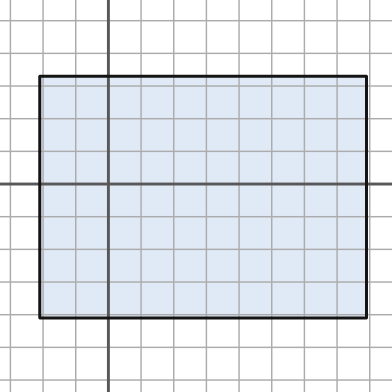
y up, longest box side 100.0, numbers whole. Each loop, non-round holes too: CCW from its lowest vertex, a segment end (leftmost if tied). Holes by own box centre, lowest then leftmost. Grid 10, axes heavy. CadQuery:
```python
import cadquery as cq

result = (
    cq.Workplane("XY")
    .moveTo(-21.0, -41.0)
    .lineTo(79.0, -41.0)
    .lineTo(79.0, 33.0)
    .lineTo(-21.0, 33.0)
    .close()
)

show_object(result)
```